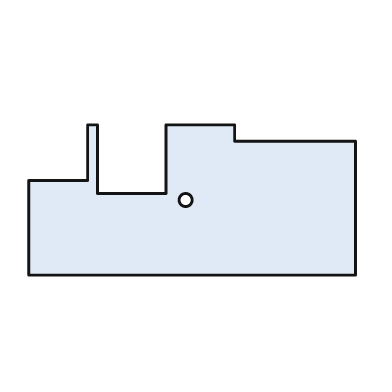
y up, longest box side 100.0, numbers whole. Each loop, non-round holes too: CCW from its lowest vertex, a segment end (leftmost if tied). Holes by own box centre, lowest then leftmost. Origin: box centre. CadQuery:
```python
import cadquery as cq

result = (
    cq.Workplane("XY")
    .moveTo(-50.0, -23.0)
    .lineTo(50.0, -23.0)
    .lineTo(50.0, 18.0)
    .lineTo(13.0, 18.0)
    .lineTo(13.0, 23.0)
    .lineTo(-8.0, 23.0)
    .lineTo(-8.0, 2.0)
    .lineTo(-29.0, 2.0)
    .lineTo(-29.0, 23.0)
    .lineTo(-32.0, 23.0)
    .lineTo(-32.0, 6.0)
    .lineTo(-50.0, 6.0)
    .close()
    .moveTo(-2.0, 0.0)
    .circle(2.0)
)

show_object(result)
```